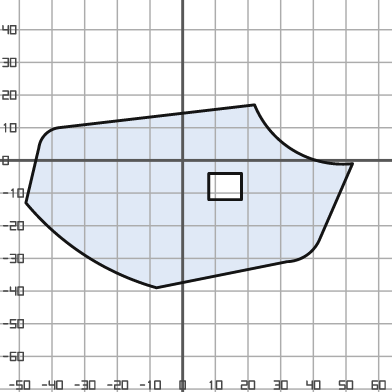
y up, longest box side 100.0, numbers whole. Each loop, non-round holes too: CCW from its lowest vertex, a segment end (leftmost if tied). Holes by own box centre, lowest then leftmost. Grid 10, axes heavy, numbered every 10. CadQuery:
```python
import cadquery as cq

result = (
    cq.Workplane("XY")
    .moveTo(-8.0, -39.0)
    .lineTo(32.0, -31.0)
    .threePointArc((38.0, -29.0), (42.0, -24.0))
    .lineTo(52.0, -1.0)
    .threePointArc((34.0, 3.0), (22.0, 17.0))
    .lineTo(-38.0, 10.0)
    .threePointArc((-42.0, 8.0), (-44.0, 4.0))
    .lineTo(-48.0, -13.0)
    .threePointArc((-30.0, -29.0), (-8.0, -39.0))
    .close()
    .moveTo(8.0, -12.0)
    .lineTo(18.0, -12.0)
    .lineTo(18.0, -4.0)
    .lineTo(8.0, -4.0)
    .close()
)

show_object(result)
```